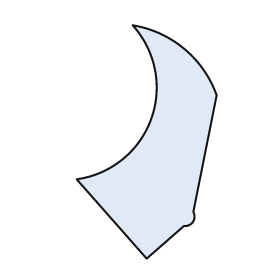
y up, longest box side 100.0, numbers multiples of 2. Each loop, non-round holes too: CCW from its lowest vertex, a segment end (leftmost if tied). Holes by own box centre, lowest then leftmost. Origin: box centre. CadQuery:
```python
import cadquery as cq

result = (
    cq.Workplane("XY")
    .moveTo(0.0, -50.0)
    .lineTo(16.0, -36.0)
    .threePointArc((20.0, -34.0), (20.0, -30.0))
    .lineTo(30.0, 20.0)
    .threePointArc((16.0, 40.0), (-6.0, 50.0))
    .threePointArc((2.0, 10.0), (-30.0, -16.0))
    .close()
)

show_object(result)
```